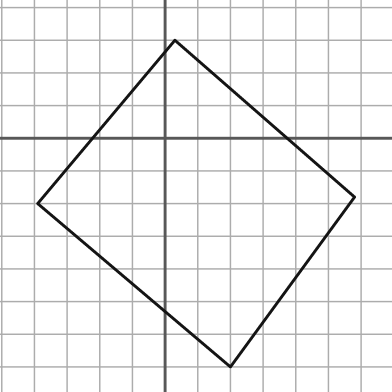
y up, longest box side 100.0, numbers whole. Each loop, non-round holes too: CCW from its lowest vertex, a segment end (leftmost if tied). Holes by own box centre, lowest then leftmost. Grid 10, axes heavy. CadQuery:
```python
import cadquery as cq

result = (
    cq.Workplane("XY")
    .moveTo(20.0, -70.0)
    .lineTo(58.0, -18.0)
    .lineTo(3.0, 30.0)
    .lineTo(-39.0, -20.0)
    .close()
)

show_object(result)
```